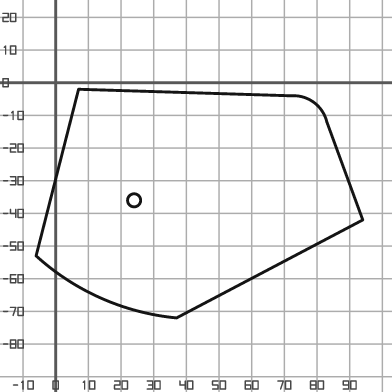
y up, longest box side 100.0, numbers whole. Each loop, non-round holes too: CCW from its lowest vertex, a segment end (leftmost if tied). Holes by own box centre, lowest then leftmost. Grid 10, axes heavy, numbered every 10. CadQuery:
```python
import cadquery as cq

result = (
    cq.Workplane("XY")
    .moveTo(37.0, -72.0)
    .lineTo(94.0, -42.0)
    .lineTo(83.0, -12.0)
    .threePointArc((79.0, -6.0), (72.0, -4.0))
    .lineTo(7.0, -2.0)
    .lineTo(-6.0, -53.0)
    .threePointArc((14.0, -66.0), (37.0, -72.0))
    .close()
    .moveTo(24.0, -36.0)
    .circle(2.0)
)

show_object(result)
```